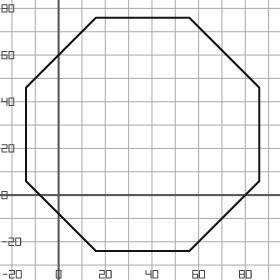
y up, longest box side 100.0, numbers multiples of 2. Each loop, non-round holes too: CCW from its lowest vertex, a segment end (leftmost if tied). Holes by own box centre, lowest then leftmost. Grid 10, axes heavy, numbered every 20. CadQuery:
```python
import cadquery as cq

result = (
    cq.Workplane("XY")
    .moveTo(16.0, -24.0)
    .lineTo(56.0, -24.0)
    .lineTo(86.0, 6.0)
    .lineTo(86.0, 46.0)
    .lineTo(56.0, 76.0)
    .lineTo(16.0, 76.0)
    .lineTo(-14.0, 46.0)
    .lineTo(-14.0, 6.0)
    .close()
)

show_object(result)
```